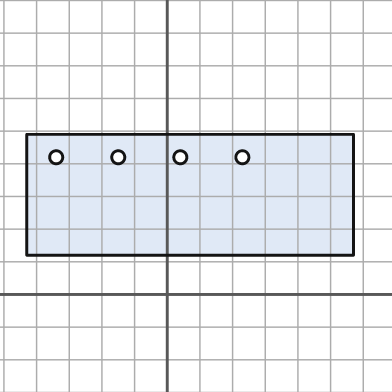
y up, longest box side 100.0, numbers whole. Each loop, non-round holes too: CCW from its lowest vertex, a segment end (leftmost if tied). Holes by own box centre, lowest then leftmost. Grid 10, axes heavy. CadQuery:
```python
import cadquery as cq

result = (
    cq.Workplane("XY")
    .moveTo(-43.0, 12.0)
    .lineTo(57.0, 12.0)
    .lineTo(57.0, 49.0)
    .lineTo(-43.0, 49.0)
    .close()
    .moveTo(-34.0, 42.0)
    .circle(2.0)
    .moveTo(-15.0, 42.0)
    .circle(2.0)
    .moveTo(4.0, 42.0)
    .circle(2.0)
    .moveTo(23.0, 42.0)
    .circle(2.0)
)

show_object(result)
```